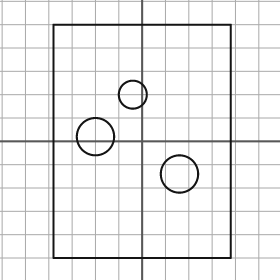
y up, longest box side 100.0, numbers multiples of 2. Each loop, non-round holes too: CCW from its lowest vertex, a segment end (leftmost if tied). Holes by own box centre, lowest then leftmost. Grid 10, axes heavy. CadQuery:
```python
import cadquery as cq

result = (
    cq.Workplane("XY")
    .moveTo(-38.0, -50.0)
    .lineTo(38.0, -50.0)
    .lineTo(38.0, 50.0)
    .lineTo(-38.0, 50.0)
    .close()
    .moveTo(16.0, -14.0)
    .circle(8.0)
    .moveTo(-20.0, 2.0)
    .circle(8.0)
    .moveTo(-4.0, 20.0)
    .circle(6.0)
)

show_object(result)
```